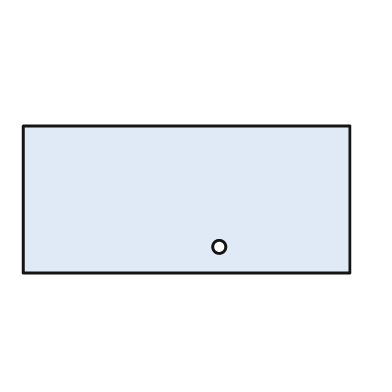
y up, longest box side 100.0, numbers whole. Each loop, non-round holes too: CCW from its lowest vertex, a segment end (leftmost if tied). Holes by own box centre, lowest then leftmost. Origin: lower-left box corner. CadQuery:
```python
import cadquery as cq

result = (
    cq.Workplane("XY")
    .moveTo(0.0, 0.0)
    .lineTo(100.0, 0.0)
    .lineTo(100.0, 45.0)
    .lineTo(0.0, 45.0)
    .close()
    .moveTo(60.0, 8.0)
    .circle(2.0)
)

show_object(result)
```